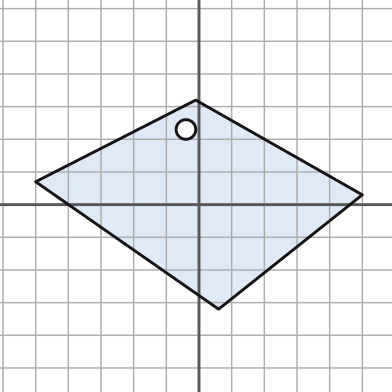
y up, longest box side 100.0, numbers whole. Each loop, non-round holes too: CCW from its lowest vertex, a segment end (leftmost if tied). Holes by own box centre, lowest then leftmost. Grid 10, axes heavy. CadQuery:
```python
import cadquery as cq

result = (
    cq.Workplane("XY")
    .moveTo(6.0, -32.0)
    .lineTo(50.0, 3.0)
    .lineTo(-1.0, 32.0)
    .lineTo(-50.0, 7.0)
    .close()
    .moveTo(-4.0, 23.0)
    .circle(3.0)
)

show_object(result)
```